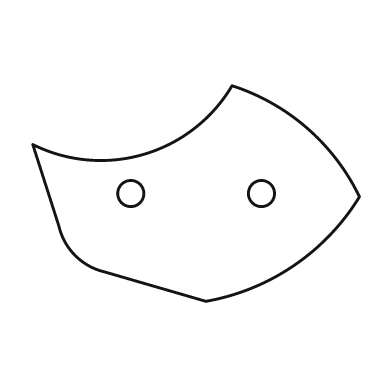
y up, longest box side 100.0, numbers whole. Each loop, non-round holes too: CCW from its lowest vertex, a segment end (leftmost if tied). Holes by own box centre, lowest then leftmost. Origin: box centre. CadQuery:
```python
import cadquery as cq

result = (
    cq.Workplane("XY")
    .moveTo(3.0, -33.0)
    .threePointArc((30.0, -22.0), (50.0, -1.0))
    .threePointArc((34.0, 20.0), (11.0, 33.0))
    .threePointArc((-16.0, 12.0), (-50.0, 15.0))
    .lineTo(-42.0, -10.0)
    .threePointArc((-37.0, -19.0), (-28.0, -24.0))
    .close()
    .moveTo(-20.0, 0.0)
    .circle(4.0)
    .moveTo(20.0, 0.0)
    .circle(4.0)
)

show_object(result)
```